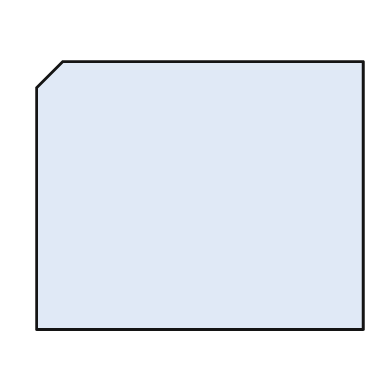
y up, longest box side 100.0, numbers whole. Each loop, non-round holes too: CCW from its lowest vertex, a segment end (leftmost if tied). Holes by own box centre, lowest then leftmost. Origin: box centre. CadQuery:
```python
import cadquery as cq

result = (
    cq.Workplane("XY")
    .moveTo(-50.0, -41.0)
    .lineTo(50.0, -41.0)
    .lineTo(50.0, 41.0)
    .lineTo(-42.0, 41.0)
    .lineTo(-50.0, 33.0)
    .close()
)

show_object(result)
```